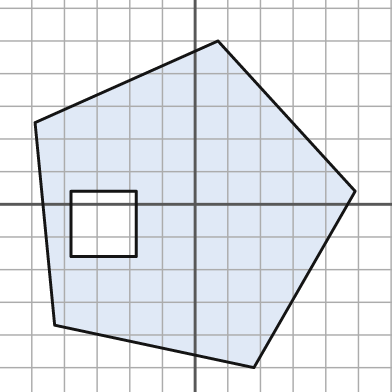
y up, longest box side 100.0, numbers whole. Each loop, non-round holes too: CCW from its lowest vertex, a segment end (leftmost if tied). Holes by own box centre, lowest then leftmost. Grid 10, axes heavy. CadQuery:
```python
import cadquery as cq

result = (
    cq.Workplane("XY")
    .moveTo(18.0, -50.0)
    .lineTo(49.0, 4.0)
    .lineTo(7.0, 50.0)
    .lineTo(-49.0, 25.0)
    .lineTo(-43.0, -37.0)
    .close()
    .moveTo(-38.0, -16.0)
    .lineTo(-18.0, -16.0)
    .lineTo(-18.0, 4.0)
    .lineTo(-38.0, 4.0)
    .close()
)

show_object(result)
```